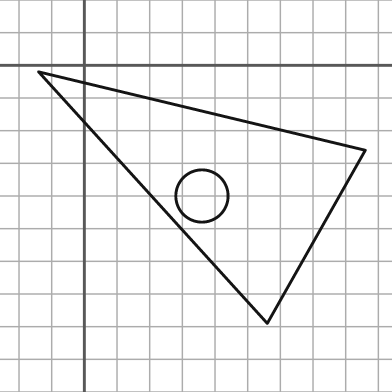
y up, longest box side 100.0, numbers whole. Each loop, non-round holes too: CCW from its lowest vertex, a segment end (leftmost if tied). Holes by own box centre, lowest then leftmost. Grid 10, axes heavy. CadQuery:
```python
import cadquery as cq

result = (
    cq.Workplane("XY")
    .moveTo(56.0, -79.0)
    .lineTo(86.0, -26.0)
    .lineTo(-14.0, -2.0)
    .close()
    .moveTo(36.0, -40.0)
    .circle(8.0)
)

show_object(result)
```